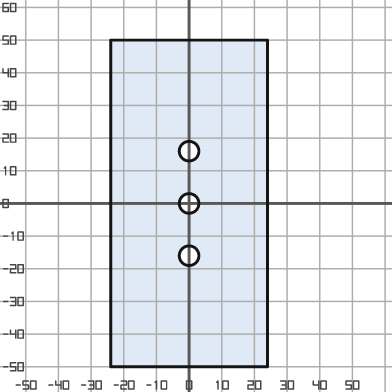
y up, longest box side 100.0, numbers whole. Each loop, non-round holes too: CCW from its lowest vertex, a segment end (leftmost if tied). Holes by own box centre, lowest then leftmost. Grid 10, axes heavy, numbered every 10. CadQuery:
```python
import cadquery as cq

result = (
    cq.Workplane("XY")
    .moveTo(-24.0, -50.0)
    .lineTo(24.0, -50.0)
    .lineTo(24.0, 50.0)
    .lineTo(-24.0, 50.0)
    .close()
    .moveTo(0.0, -16.0)
    .circle(3.0)
    .moveTo(0.0, 0.0)
    .circle(3.0)
    .moveTo(0.0, 16.0)
    .circle(3.0)
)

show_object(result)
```